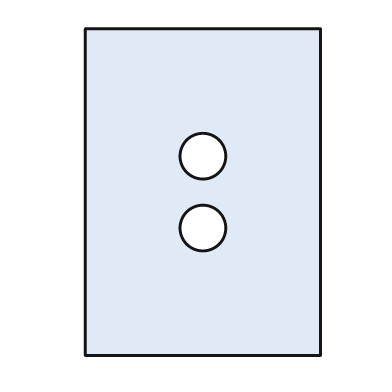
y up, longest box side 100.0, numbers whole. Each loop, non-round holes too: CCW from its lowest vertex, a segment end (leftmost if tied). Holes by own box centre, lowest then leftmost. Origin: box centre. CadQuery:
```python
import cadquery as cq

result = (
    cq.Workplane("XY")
    .moveTo(-36.0, -50.0)
    .lineTo(36.0, -50.0)
    .lineTo(36.0, 50.0)
    .lineTo(-36.0, 50.0)
    .close()
    .moveTo(0.0, -11.0)
    .circle(7.0)
    .moveTo(0.0, 11.0)
    .circle(7.0)
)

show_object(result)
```